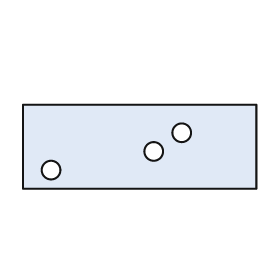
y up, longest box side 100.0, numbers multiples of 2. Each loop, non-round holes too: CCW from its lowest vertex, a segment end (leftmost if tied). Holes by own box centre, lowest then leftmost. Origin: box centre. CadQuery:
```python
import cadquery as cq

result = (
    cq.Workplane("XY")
    .moveTo(-50.0, -18.0)
    .lineTo(50.0, -18.0)
    .lineTo(50.0, 18.0)
    .lineTo(-50.0, 18.0)
    .close()
    .moveTo(-38.0, -10.0)
    .circle(4.0)
    .moveTo(6.0, -2.0)
    .circle(4.0)
    .moveTo(18.0, 6.0)
    .circle(4.0)
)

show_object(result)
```